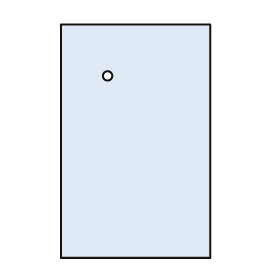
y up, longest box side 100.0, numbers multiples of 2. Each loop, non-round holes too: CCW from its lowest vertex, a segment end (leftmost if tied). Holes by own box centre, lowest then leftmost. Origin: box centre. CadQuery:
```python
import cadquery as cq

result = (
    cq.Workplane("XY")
    .moveTo(-32.0, -50.0)
    .lineTo(32.0, -50.0)
    .lineTo(32.0, 50.0)
    .lineTo(-32.0, 50.0)
    .close()
    .moveTo(-12.0, 28.0)
    .circle(2.0)
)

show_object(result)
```